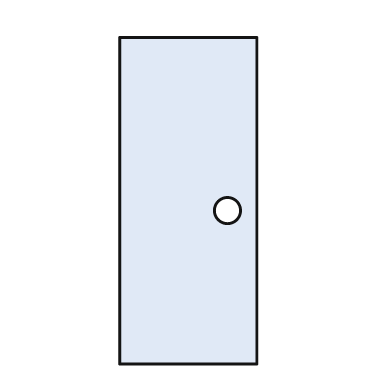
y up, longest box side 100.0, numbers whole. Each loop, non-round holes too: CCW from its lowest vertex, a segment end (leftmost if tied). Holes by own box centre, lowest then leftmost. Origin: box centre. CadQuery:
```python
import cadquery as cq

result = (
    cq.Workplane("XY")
    .moveTo(-21.0, -50.0)
    .lineTo(21.0, -50.0)
    .lineTo(21.0, 50.0)
    .lineTo(-21.0, 50.0)
    .close()
    .moveTo(12.0, -3.0)
    .circle(4.0)
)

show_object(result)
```